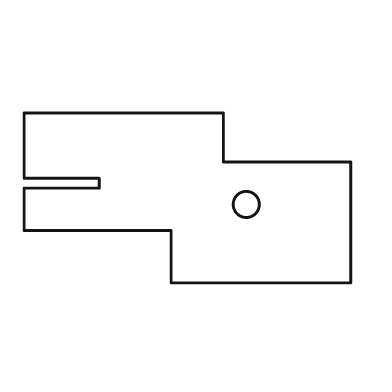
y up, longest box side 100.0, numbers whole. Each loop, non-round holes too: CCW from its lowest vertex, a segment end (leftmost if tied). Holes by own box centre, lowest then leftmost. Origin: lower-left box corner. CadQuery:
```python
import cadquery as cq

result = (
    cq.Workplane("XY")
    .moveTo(45.0, 0.0)
    .lineTo(100.0, 0.0)
    .lineTo(100.0, 37.0)
    .lineTo(61.0, 37.0)
    .lineTo(61.0, 52.0)
    .lineTo(0.0, 52.0)
    .lineTo(0.0, 32.0)
    .lineTo(23.0, 32.0)
    .lineTo(23.0, 29.0)
    .lineTo(0.0, 29.0)
    .lineTo(0.0, 16.0)
    .lineTo(45.0, 16.0)
    .close()
    .moveTo(68.0, 24.0)
    .circle(4.0)
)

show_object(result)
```